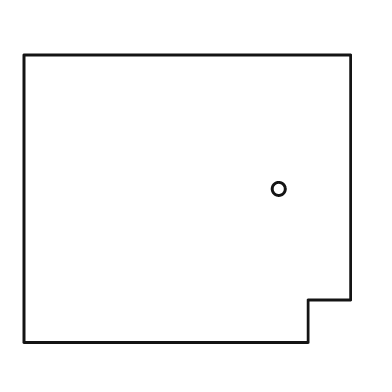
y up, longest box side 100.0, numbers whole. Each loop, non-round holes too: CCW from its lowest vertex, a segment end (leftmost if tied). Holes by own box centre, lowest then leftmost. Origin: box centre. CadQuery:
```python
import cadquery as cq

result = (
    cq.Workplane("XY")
    .moveTo(-50.0, -44.0)
    .lineTo(37.0, -44.0)
    .lineTo(37.0, -31.0)
    .lineTo(50.0, -31.0)
    .lineTo(50.0, 44.0)
    .lineTo(-50.0, 44.0)
    .close()
    .moveTo(28.0, 3.0)
    .circle(2.0)
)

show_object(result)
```